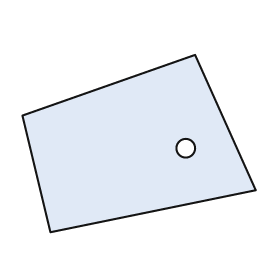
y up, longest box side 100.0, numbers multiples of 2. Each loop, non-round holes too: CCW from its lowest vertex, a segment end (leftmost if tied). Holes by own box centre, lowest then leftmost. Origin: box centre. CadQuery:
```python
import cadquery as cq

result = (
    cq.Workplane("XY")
    .moveTo(-38.0, -38.0)
    .lineTo(50.0, -20.0)
    .lineTo(24.0, 38.0)
    .lineTo(-50.0, 12.0)
    .close()
    .moveTo(20.0, -2.0)
    .circle(4.0)
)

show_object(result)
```